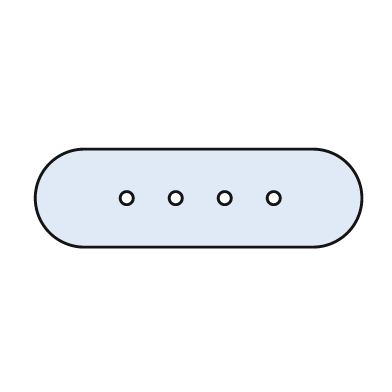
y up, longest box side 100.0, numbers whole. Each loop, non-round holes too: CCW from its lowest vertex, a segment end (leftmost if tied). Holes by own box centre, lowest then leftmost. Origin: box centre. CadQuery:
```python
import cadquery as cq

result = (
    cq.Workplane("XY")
    .moveTo(-35.0, -15.0)
    .lineTo(35.0, -15.0)
    .threePointArc((50.0, 0.0), (35.0, 15.0))
    .lineTo(-35.0, 15.0)
    .threePointArc((-50.0, 0.0), (-35.0, -15.0))
    .close()
    .moveTo(-22.0, 0.0)
    .circle(2.0)
    .moveTo(-7.0, 0.0)
    .circle(2.0)
    .moveTo(8.0, 0.0)
    .circle(2.0)
    .moveTo(23.0, 0.0)
    .circle(2.0)
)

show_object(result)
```